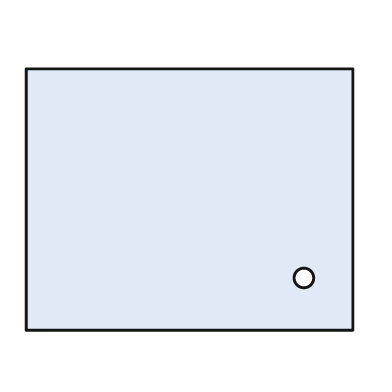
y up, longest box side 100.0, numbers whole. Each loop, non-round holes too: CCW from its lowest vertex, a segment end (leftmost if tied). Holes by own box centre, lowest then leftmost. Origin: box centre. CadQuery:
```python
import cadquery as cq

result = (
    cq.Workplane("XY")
    .moveTo(-50.0, -40.0)
    .lineTo(50.0, -40.0)
    .lineTo(50.0, 40.0)
    .lineTo(-50.0, 40.0)
    .close()
    .moveTo(35.0, -24.0)
    .circle(3.0)
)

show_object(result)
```